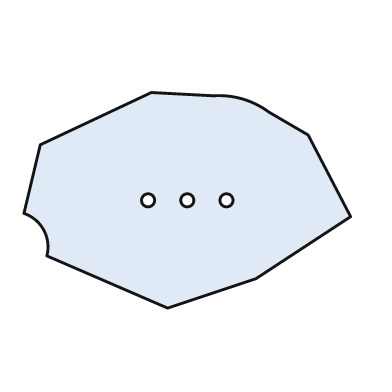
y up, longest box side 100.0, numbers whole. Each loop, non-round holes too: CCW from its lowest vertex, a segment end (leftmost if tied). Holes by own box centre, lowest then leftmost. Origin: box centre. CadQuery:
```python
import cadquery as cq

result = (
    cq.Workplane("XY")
    .moveTo(-6.0, -33.0)
    .lineTo(21.0, -24.0)
    .lineTo(50.0, -5.0)
    .lineTo(37.0, 20.0)
    .lineTo(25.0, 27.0)
    .threePointArc((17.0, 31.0), (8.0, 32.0))
    .lineTo(-11.0, 33.0)
    .lineTo(-45.0, 17.0)
    .lineTo(-50.0, -4.0)
    .threePointArc((-44.0, -9.0), (-43.0, -17.0))
    .close()
    .moveTo(-12.0, 0.0)
    .circle(2.0)
    .moveTo(0.0, 0.0)
    .circle(2.0)
    .moveTo(12.0, 0.0)
    .circle(2.0)
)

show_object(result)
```